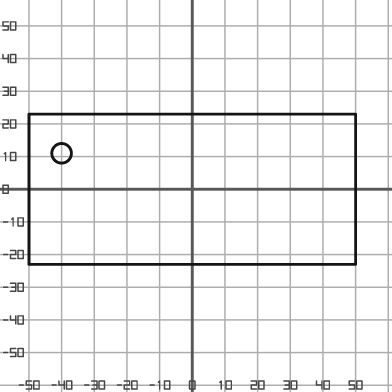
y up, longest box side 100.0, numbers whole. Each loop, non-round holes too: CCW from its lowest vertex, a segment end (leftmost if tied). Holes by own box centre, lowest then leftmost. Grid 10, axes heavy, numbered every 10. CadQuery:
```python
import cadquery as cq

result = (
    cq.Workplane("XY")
    .moveTo(-50.0, -23.0)
    .lineTo(50.0, -23.0)
    .lineTo(50.0, 23.0)
    .lineTo(-50.0, 23.0)
    .close()
    .moveTo(-40.0, 11.0)
    .circle(3.0)
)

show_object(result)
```